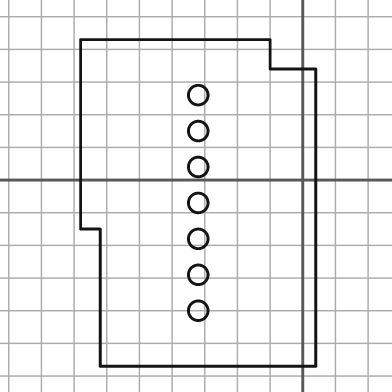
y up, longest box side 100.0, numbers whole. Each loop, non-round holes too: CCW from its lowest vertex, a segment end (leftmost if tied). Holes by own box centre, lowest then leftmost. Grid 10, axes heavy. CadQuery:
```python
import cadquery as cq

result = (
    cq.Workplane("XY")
    .moveTo(-62.0, -57.0)
    .lineTo(4.0, -57.0)
    .lineTo(4.0, 34.0)
    .lineTo(-10.0, 34.0)
    .lineTo(-10.0, 43.0)
    .lineTo(-68.0, 43.0)
    .lineTo(-68.0, -15.0)
    .lineTo(-62.0, -15.0)
    .close()
    .moveTo(-32.0, -40.0)
    .circle(3.0)
    .moveTo(-32.0, -29.0)
    .circle(3.0)
    .moveTo(-32.0, -18.0)
    .circle(3.0)
    .moveTo(-32.0, -7.0)
    .circle(3.0)
    .moveTo(-32.0, 4.0)
    .circle(3.0)
    .moveTo(-32.0, 15.0)
    .circle(3.0)
    .moveTo(-32.0, 26.0)
    .circle(3.0)
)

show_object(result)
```